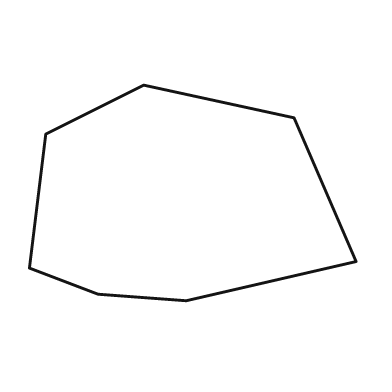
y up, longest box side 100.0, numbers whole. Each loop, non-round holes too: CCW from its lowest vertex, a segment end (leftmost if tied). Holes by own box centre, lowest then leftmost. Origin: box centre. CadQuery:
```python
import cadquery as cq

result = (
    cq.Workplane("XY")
    .moveTo(-2.0, -33.0)
    .lineTo(50.0, -21.0)
    .lineTo(31.0, 23.0)
    .lineTo(-15.0, 33.0)
    .lineTo(-45.0, 18.0)
    .lineTo(-50.0, -23.0)
    .lineTo(-29.0, -31.0)
    .close()
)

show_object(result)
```